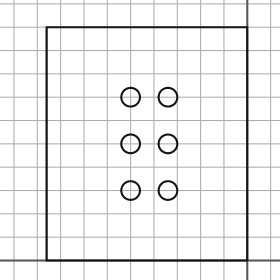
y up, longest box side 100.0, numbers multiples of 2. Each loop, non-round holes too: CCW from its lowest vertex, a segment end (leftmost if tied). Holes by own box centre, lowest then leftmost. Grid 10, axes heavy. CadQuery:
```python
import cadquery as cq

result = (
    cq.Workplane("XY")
    .moveTo(-86.0, 0.0)
    .lineTo(0.0, 0.0)
    .lineTo(0.0, 100.0)
    .lineTo(-86.0, 100.0)
    .close()
    .moveTo(-50.0, 30.0)
    .circle(4.0)
    .moveTo(-34.0, 30.0)
    .circle(4.0)
    .moveTo(-50.0, 50.0)
    .circle(4.0)
    .moveTo(-34.0, 50.0)
    .circle(4.0)
    .moveTo(-50.0, 70.0)
    .circle(4.0)
    .moveTo(-34.0, 70.0)
    .circle(4.0)
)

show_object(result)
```